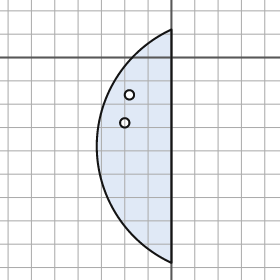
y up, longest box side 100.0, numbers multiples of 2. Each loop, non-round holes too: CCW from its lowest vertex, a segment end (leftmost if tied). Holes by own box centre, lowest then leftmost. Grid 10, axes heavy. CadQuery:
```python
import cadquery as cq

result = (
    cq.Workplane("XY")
    .moveTo(0.0, -88.0)
    .lineTo(0.0, 12.0)
    .threePointArc((-32.0, -38.0), (0.0, -88.0))
    .close()
    .moveTo(-20.0, -28.0)
    .circle(2.0)
    .moveTo(-18.0, -16.0)
    .circle(2.0)
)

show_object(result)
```